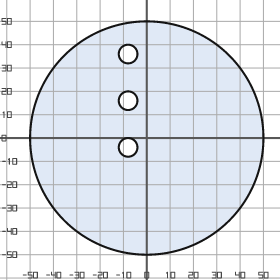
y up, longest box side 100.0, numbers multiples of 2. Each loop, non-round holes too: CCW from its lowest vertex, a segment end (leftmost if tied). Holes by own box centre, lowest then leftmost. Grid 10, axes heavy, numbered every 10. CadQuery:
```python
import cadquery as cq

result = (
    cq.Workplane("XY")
    .moveTo(0.0, 0.0)
    .circle(50.0)
    .moveTo(-8.0, -4.0)
    .circle(4.0)
    .moveTo(-8.0, 16.0)
    .circle(4.0)
    .moveTo(-8.0, 36.0)
    .circle(4.0)
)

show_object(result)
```